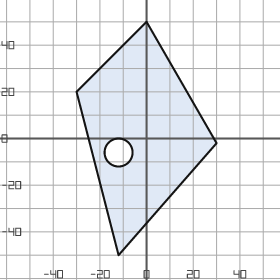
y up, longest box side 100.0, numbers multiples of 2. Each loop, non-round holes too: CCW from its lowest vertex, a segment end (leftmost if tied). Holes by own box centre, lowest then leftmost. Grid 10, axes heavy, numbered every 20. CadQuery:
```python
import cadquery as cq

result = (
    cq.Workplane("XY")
    .moveTo(-12.0, -50.0)
    .lineTo(30.0, -2.0)
    .lineTo(0.0, 50.0)
    .lineTo(-30.0, 20.0)
    .close()
    .moveTo(-12.0, -6.0)
    .circle(6.0)
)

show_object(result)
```